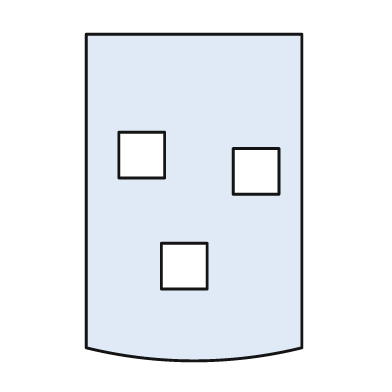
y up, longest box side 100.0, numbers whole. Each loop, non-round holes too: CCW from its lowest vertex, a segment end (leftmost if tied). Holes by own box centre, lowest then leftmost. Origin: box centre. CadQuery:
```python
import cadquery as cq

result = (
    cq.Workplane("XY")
    .moveTo(-33.0, -46.0)
    .threePointArc((0.0, -50.0), (33.0, -46.0))
    .lineTo(33.0, 50.0)
    .lineTo(-33.0, 50.0)
    .close()
    .moveTo(-10.0, -28.0)
    .lineTo(4.0, -28.0)
    .lineTo(4.0, -14.0)
    .lineTo(-10.0, -14.0)
    .close()
    .moveTo(12.0, 1.0)
    .lineTo(26.0, 1.0)
    .lineTo(26.0, 15.0)
    .lineTo(12.0, 15.0)
    .close()
    .moveTo(-23.0, 6.0)
    .lineTo(-9.0, 6.0)
    .lineTo(-9.0, 20.0)
    .lineTo(-23.0, 20.0)
    .close()
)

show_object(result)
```